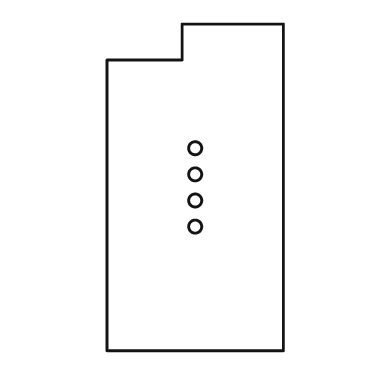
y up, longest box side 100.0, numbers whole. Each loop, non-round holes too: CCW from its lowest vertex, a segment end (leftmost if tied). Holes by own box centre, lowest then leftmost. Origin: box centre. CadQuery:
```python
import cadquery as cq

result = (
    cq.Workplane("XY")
    .moveTo(-27.0, -50.0)
    .lineTo(27.0, -50.0)
    .lineTo(27.0, 50.0)
    .lineTo(-4.0, 50.0)
    .lineTo(-4.0, 39.0)
    .lineTo(-27.0, 39.0)
    .close()
    .moveTo(0.0, -12.0)
    .circle(2.0)
    .moveTo(0.0, -4.0)
    .circle(2.0)
    .moveTo(0.0, 4.0)
    .circle(2.0)
    .moveTo(0.0, 12.0)
    .circle(2.0)
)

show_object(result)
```